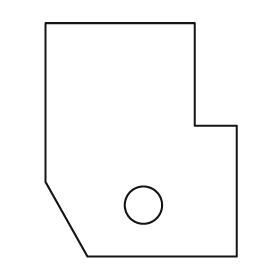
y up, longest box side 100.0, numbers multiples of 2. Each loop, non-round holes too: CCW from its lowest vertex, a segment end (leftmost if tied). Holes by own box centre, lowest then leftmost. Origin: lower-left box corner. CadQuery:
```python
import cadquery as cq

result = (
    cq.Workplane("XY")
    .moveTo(18.0, 0.0)
    .lineTo(82.0, 0.0)
    .lineTo(82.0, 56.0)
    .lineTo(64.0, 56.0)
    .lineTo(64.0, 100.0)
    .lineTo(0.0, 100.0)
    .lineTo(0.0, 32.0)
    .close()
    .moveTo(42.0, 22.0)
    .circle(8.0)
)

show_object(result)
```